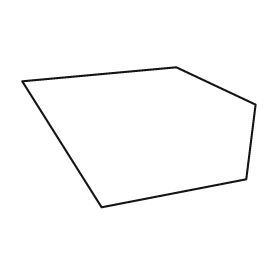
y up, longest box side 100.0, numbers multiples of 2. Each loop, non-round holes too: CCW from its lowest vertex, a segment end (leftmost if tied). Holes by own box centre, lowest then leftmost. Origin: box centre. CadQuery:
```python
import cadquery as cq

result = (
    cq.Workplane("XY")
    .moveTo(-16.0, -30.0)
    .lineTo(46.0, -18.0)
    .lineTo(50.0, 14.0)
    .lineTo(16.0, 30.0)
    .lineTo(-50.0, 24.0)
    .close()
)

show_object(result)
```